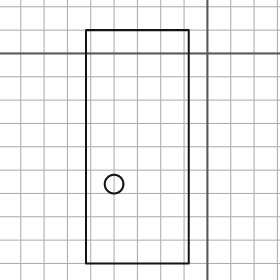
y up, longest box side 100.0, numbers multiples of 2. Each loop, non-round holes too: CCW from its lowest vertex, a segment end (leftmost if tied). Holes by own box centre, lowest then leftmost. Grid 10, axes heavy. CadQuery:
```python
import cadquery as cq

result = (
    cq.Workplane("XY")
    .moveTo(-52.0, -90.0)
    .lineTo(-8.0, -90.0)
    .lineTo(-8.0, 10.0)
    .lineTo(-52.0, 10.0)
    .close()
    .moveTo(-40.0, -56.0)
    .circle(4.0)
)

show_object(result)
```